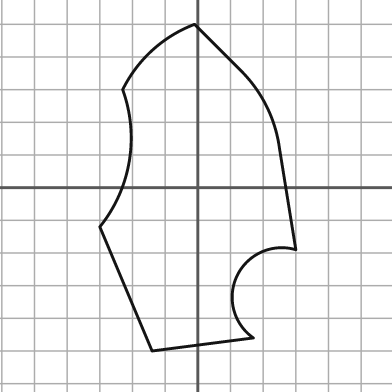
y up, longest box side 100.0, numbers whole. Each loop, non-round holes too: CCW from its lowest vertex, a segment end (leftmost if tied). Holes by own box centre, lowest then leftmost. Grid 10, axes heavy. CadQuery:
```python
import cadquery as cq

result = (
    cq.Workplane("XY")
    .moveTo(-14.0, -50.0)
    .lineTo(17.0, -46.0)
    .threePointArc((12.0, -27.0), (30.0, -19.0))
    .lineTo(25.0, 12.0)
    .threePointArc((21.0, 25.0), (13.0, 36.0))
    .lineTo(-1.0, 50.0)
    .threePointArc((-14.0, 42.0), (-23.0, 30.0))
    .threePointArc((-21.0, 8.0), (-30.0, -12.0))
    .close()
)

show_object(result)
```